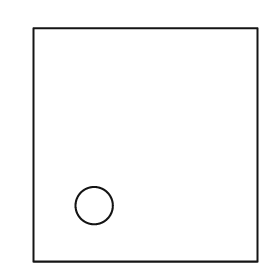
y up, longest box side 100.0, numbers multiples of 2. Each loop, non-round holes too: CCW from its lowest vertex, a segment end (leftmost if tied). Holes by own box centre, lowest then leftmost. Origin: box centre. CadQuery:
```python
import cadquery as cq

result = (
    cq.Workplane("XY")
    .moveTo(-48.0, -50.0)
    .lineTo(48.0, -50.0)
    .lineTo(48.0, 50.0)
    .lineTo(-48.0, 50.0)
    .close()
    .moveTo(-22.0, -26.0)
    .circle(8.0)
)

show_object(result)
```